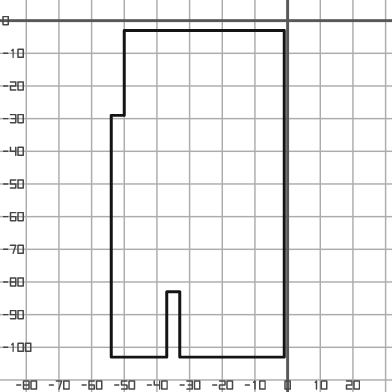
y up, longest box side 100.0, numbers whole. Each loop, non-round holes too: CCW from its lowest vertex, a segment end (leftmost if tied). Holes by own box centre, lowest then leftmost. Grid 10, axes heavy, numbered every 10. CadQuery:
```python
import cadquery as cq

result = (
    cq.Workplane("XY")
    .moveTo(-54.0, -103.0)
    .lineTo(-37.0, -103.0)
    .lineTo(-37.0, -83.0)
    .lineTo(-33.0, -83.0)
    .lineTo(-33.0, -103.0)
    .lineTo(-1.0, -103.0)
    .lineTo(-1.0, -3.0)
    .lineTo(-50.0, -3.0)
    .lineTo(-50.0, -29.0)
    .lineTo(-54.0, -29.0)
    .close()
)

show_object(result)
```